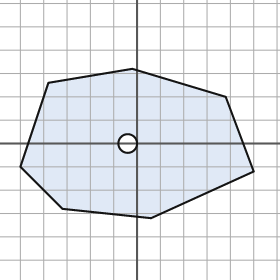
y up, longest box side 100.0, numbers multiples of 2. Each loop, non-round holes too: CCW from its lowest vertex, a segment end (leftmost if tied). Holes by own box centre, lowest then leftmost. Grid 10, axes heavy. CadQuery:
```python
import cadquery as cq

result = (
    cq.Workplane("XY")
    .moveTo(6.0, -32.0)
    .lineTo(50.0, -12.0)
    .lineTo(38.0, 20.0)
    .lineTo(-2.0, 32.0)
    .lineTo(-38.0, 26.0)
    .lineTo(-50.0, -10.0)
    .lineTo(-32.0, -28.0)
    .close()
    .moveTo(-4.0, 0.0)
    .circle(4.0)
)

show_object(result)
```